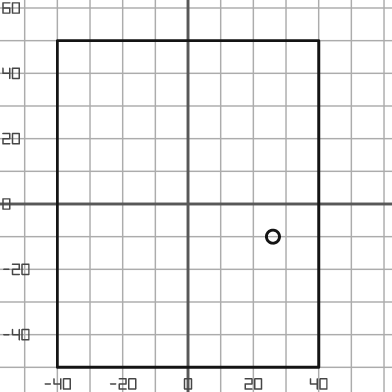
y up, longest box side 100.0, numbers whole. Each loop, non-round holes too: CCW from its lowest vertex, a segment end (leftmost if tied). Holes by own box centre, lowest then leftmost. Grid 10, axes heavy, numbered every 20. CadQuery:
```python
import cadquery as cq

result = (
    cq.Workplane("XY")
    .moveTo(-40.0, -50.0)
    .lineTo(40.0, -50.0)
    .lineTo(40.0, 50.0)
    .lineTo(-40.0, 50.0)
    .close()
    .moveTo(26.0, -10.0)
    .circle(2.0)
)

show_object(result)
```